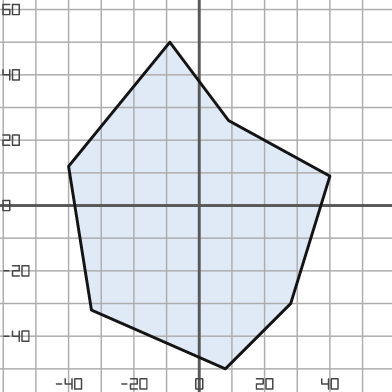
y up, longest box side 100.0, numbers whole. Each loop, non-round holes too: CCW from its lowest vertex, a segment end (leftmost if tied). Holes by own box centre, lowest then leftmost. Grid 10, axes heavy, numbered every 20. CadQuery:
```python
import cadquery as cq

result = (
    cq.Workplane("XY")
    .moveTo(8.0, -50.0)
    .lineTo(28.0, -30.0)
    .lineTo(40.0, 9.0)
    .lineTo(9.0, 26.0)
    .lineTo(-9.0, 50.0)
    .lineTo(-40.0, 12.0)
    .lineTo(-33.0, -32.0)
    .close()
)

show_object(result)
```